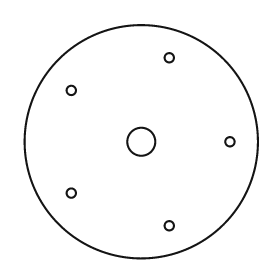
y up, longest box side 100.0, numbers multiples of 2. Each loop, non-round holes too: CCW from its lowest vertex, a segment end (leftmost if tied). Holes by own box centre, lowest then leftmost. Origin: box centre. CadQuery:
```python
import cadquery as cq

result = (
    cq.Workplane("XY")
    .moveTo(0.0, 0.0)
    .circle(50.0)
    .moveTo(12.0, -36.0)
    .circle(2.0)
    .moveTo(-30.0, -22.0)
    .circle(2.0)
    .moveTo(0.0, 0.0)
    .circle(6.0)
    .moveTo(38.0, 0.0)
    .circle(2.0)
    .moveTo(-30.0, 22.0)
    .circle(2.0)
    .moveTo(12.0, 36.0)
    .circle(2.0)
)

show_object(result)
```